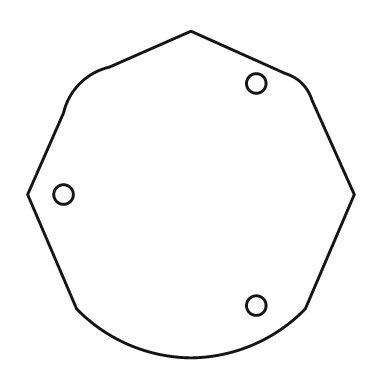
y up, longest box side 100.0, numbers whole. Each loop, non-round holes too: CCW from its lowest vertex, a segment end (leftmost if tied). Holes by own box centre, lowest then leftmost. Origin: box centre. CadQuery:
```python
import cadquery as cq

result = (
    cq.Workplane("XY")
    .moveTo(0.0, -50.0)
    .threePointArc((19.0, -46.0), (35.0, -35.0))
    .lineTo(50.0, 0.0)
    .lineTo(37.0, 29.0)
    .threePointArc((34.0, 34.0), (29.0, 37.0))
    .lineTo(0.0, 50.0)
    .lineTo(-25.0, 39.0)
    .threePointArc((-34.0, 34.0), (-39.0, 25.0))
    .lineTo(-50.0, 0.0)
    .lineTo(-35.0, -35.0)
    .threePointArc((-19.0, -46.0), (0.0, -50.0))
    .close()
    .moveTo(20.0, -34.0)
    .circle(3.0)
    .moveTo(-39.0, 0.0)
    .circle(3.0)
    .moveTo(20.0, 34.0)
    .circle(3.0)
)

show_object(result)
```